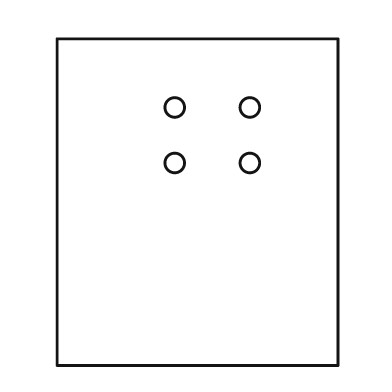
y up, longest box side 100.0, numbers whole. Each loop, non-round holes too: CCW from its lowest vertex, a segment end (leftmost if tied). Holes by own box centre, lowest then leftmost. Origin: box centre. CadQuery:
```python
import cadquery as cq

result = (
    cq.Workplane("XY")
    .moveTo(-43.0, -50.0)
    .lineTo(43.0, -50.0)
    .lineTo(43.0, 50.0)
    .lineTo(-43.0, 50.0)
    .close()
    .moveTo(-7.0, 12.0)
    .circle(3.0)
    .moveTo(16.0, 12.0)
    .circle(3.0)
    .moveTo(-7.0, 29.0)
    .circle(3.0)
    .moveTo(16.0, 29.0)
    .circle(3.0)
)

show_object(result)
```